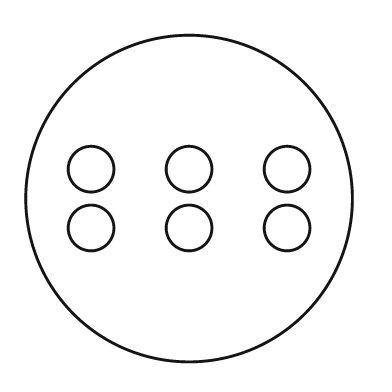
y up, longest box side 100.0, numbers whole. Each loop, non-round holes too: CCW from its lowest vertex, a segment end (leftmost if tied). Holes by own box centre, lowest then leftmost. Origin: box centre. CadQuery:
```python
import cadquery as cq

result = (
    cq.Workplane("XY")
    .moveTo(0.0, 0.0)
    .circle(50.0)
    .moveTo(-30.0, -9.0)
    .circle(7.0)
    .moveTo(0.0, -9.0)
    .circle(7.0)
    .moveTo(30.0, -9.0)
    .circle(7.0)
    .moveTo(-30.0, 9.0)
    .circle(7.0)
    .moveTo(0.0, 9.0)
    .circle(7.0)
    .moveTo(30.0, 9.0)
    .circle(7.0)
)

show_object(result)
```